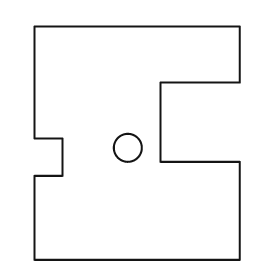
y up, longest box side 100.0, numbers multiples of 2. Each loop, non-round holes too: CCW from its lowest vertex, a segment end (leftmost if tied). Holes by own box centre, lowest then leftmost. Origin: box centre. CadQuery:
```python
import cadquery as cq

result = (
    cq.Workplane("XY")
    .moveTo(-44.0, -50.0)
    .lineTo(44.0, -50.0)
    .lineTo(44.0, -8.0)
    .lineTo(10.0, -8.0)
    .lineTo(10.0, 26.0)
    .lineTo(44.0, 26.0)
    .lineTo(44.0, 50.0)
    .lineTo(-44.0, 50.0)
    .lineTo(-44.0, 2.0)
    .lineTo(-32.0, 2.0)
    .lineTo(-32.0, -14.0)
    .lineTo(-44.0, -14.0)
    .close()
    .moveTo(-4.0, -2.0)
    .circle(6.0)
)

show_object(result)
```